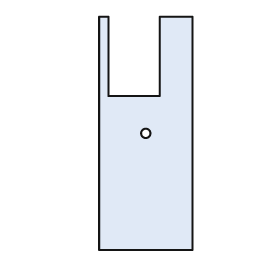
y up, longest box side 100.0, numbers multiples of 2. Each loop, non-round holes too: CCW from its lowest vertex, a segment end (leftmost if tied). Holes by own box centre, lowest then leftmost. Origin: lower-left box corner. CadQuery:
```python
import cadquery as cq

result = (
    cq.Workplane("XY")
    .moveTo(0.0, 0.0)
    .lineTo(40.0, 0.0)
    .lineTo(40.0, 100.0)
    .lineTo(26.0, 100.0)
    .lineTo(26.0, 66.0)
    .lineTo(4.0, 66.0)
    .lineTo(4.0, 100.0)
    .lineTo(0.0, 100.0)
    .close()
    .moveTo(20.0, 50.0)
    .circle(2.0)
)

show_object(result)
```